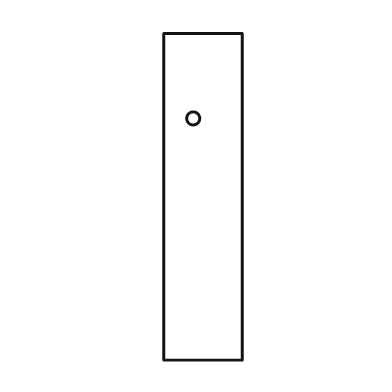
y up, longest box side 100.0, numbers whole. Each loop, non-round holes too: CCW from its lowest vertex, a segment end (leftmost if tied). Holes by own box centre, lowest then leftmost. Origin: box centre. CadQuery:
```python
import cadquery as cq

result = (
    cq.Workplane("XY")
    .moveTo(-12.0, -50.0)
    .lineTo(12.0, -50.0)
    .lineTo(12.0, 50.0)
    .lineTo(-12.0, 50.0)
    .close()
    .moveTo(-3.0, 24.0)
    .circle(2.0)
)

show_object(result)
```